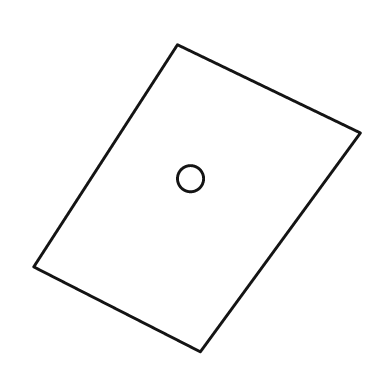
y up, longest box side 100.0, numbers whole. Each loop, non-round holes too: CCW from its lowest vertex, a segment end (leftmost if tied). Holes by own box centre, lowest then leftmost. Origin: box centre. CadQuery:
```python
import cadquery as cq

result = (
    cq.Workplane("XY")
    .moveTo(1.0, -47.0)
    .lineTo(50.0, 20.0)
    .lineTo(-6.0, 47.0)
    .lineTo(-50.0, -21.0)
    .close()
    .moveTo(-2.0, 6.0)
    .circle(4.0)
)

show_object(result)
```